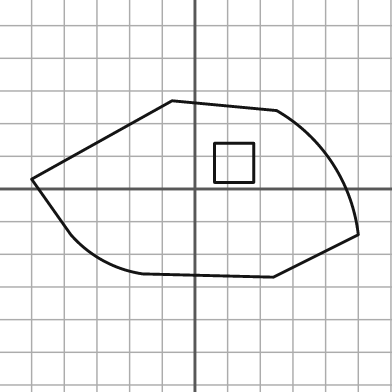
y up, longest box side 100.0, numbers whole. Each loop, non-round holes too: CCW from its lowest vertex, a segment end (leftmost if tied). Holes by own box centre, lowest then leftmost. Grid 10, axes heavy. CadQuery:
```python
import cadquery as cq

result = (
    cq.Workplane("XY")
    .moveTo(24.0, -27.0)
    .lineTo(50.0, -14.0)
    .threePointArc((42.0, 8.0), (25.0, 24.0))
    .lineTo(-7.0, 27.0)
    .lineTo(-50.0, 3.0)
    .lineTo(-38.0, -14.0)
    .threePointArc((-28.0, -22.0), (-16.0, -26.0))
    .close()
    .moveTo(6.0, 2.0)
    .lineTo(18.0, 2.0)
    .lineTo(18.0, 14.0)
    .lineTo(6.0, 14.0)
    .close()
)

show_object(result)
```